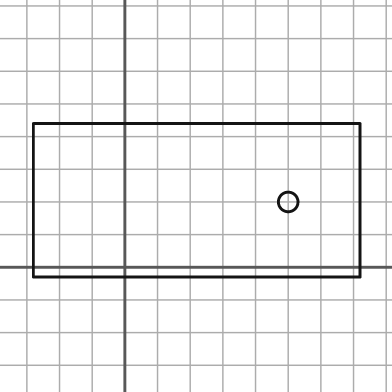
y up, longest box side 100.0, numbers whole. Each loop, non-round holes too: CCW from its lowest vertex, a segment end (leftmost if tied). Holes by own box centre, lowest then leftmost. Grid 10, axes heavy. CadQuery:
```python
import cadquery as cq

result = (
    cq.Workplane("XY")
    .moveTo(-28.0, -3.0)
    .lineTo(72.0, -3.0)
    .lineTo(72.0, 44.0)
    .lineTo(-28.0, 44.0)
    .close()
    .moveTo(50.0, 20.0)
    .circle(3.0)
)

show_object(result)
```